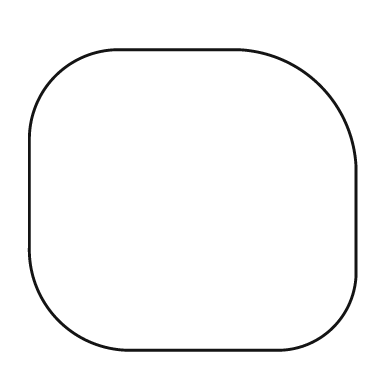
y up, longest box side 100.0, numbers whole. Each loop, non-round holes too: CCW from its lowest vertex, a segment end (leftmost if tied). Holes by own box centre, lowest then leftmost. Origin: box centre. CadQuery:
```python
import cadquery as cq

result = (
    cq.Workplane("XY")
    .moveTo(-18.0, -46.0)
    .lineTo(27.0, -46.0)
    .threePointArc((43.0, -39.0), (50.0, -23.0))
    .lineTo(50.0, 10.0)
    .threePointArc((39.0, 35.0), (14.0, 46.0))
    .lineTo(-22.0, 46.0)
    .threePointArc((-42.0, 38.0), (-50.0, 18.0))
    .lineTo(-50.0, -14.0)
    .threePointArc((-41.0, -37.0), (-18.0, -46.0))
    .close()
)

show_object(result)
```